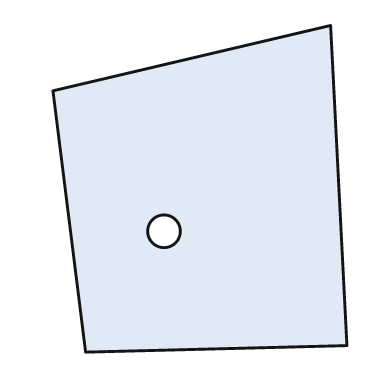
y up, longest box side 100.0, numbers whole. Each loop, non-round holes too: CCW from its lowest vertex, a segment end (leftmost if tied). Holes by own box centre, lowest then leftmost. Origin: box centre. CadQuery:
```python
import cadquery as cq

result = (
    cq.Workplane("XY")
    .moveTo(-35.0, -50.0)
    .lineTo(45.0, -48.0)
    .lineTo(40.0, 50.0)
    .lineTo(-45.0, 30.0)
    .close()
    .moveTo(-11.0, -13.0)
    .circle(5.0)
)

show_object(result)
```